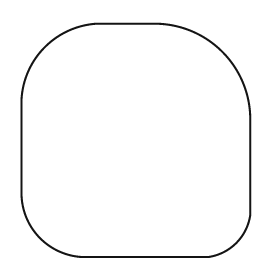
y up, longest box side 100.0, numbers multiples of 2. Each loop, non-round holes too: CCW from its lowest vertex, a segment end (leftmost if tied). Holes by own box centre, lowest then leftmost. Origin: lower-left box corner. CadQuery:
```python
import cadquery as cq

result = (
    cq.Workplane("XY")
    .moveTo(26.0, 0.0)
    .lineTo(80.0, 0.0)
    .threePointArc((92.0, 6.0), (98.0, 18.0))
    .lineTo(98.0, 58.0)
    .threePointArc((86.0, 88.0), (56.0, 100.0))
    .lineTo(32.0, 100.0)
    .threePointArc((10.0, 90.0), (0.0, 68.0))
    .lineTo(0.0, 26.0)
    .threePointArc((8.0, 8.0), (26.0, 0.0))
    .close()
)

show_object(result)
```